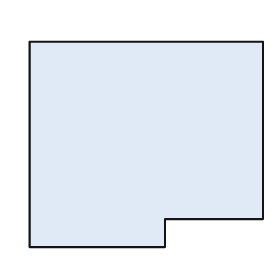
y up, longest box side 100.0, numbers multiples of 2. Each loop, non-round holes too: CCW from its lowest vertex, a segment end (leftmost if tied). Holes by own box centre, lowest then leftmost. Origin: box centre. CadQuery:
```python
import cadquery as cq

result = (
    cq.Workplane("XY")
    .moveTo(-50.0, -44.0)
    .lineTo(8.0, -44.0)
    .lineTo(8.0, -32.0)
    .lineTo(50.0, -32.0)
    .lineTo(50.0, 44.0)
    .lineTo(-50.0, 44.0)
    .close()
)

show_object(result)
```